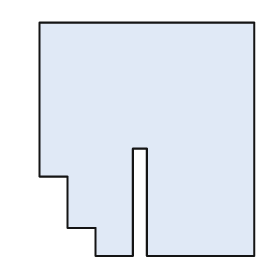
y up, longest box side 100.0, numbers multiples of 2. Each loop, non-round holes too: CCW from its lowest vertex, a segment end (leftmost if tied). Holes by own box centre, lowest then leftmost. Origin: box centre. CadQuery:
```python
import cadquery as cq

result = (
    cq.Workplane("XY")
    .moveTo(-22.0, -50.0)
    .lineTo(-6.0, -50.0)
    .lineTo(-6.0, -4.0)
    .lineTo(0.0, -4.0)
    .lineTo(0.0, -50.0)
    .lineTo(46.0, -50.0)
    .lineTo(46.0, 50.0)
    .lineTo(-46.0, 50.0)
    .lineTo(-46.0, -16.0)
    .lineTo(-34.0, -16.0)
    .lineTo(-34.0, -38.0)
    .lineTo(-22.0, -38.0)
    .close()
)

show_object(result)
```